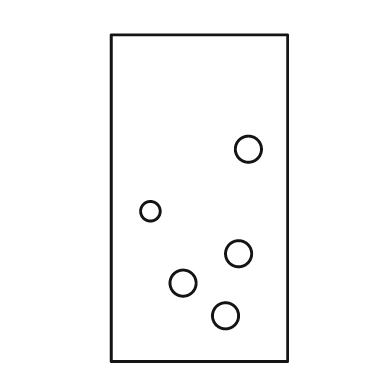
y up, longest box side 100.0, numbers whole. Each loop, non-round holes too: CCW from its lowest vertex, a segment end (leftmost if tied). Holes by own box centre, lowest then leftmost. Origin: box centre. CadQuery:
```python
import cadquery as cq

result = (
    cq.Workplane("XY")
    .moveTo(-27.0, -50.0)
    .lineTo(27.0, -50.0)
    .lineTo(27.0, 50.0)
    .lineTo(-27.0, 50.0)
    .close()
    .moveTo(8.0, -36.0)
    .circle(4.0)
    .moveTo(-5.0, -26.0)
    .circle(4.0)
    .moveTo(12.0, -17.0)
    .circle(4.0)
    .moveTo(-15.0, -4.0)
    .circle(3.0)
    .moveTo(15.0, 15.0)
    .circle(4.0)
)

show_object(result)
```